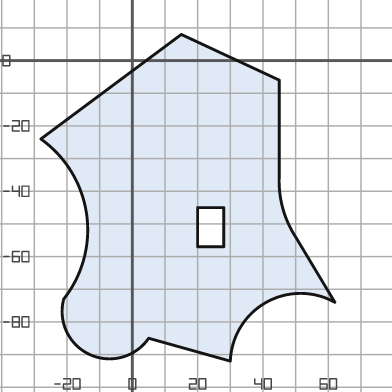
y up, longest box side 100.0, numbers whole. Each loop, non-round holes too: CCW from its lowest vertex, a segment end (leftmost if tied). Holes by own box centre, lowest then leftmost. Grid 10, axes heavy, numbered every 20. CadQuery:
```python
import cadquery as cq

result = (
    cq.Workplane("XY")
    .moveTo(30.0, -92.0)
    .threePointArc((41.0, -74.0), (62.0, -74.0))
    .lineTo(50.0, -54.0)
    .threePointArc((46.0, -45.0), (45.0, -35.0))
    .lineTo(45.0, -6.0)
    .lineTo(15.0, 8.0)
    .lineTo(-28.0, -24.0)
    .threePointArc((-14.0, -47.0), (-21.0, -73.0))
    .threePointArc((-13.0, -90.0), (5.0, -85.0))
    .close()
    .moveTo(20.0, -57.0)
    .lineTo(28.0, -57.0)
    .lineTo(28.0, -45.0)
    .lineTo(20.0, -45.0)
    .close()
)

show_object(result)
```